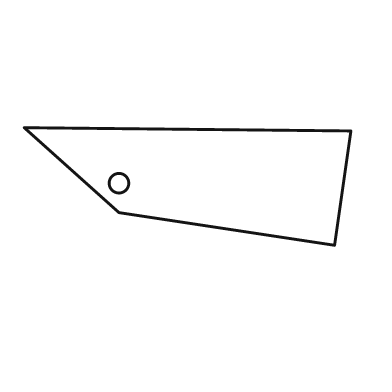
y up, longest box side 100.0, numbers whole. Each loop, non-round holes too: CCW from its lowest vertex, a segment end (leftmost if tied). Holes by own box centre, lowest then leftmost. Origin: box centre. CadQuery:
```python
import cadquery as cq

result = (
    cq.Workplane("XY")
    .moveTo(45.0, -18.0)
    .lineTo(50.0, 17.0)
    .lineTo(-50.0, 18.0)
    .lineTo(-21.0, -8.0)
    .close()
    .moveTo(-21.0, 1.0)
    .circle(3.0)
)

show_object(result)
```